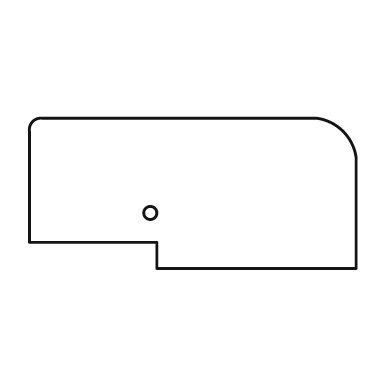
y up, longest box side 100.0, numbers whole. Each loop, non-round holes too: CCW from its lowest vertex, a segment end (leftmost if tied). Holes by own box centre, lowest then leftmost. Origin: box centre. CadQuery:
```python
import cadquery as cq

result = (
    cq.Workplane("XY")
    .moveTo(-11.0, -23.0)
    .lineTo(50.0, -23.0)
    .lineTo(50.0, 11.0)
    .threePointArc((46.0, 19.0), (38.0, 23.0))
    .lineTo(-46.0, 23.0)
    .threePointArc((-49.0, 22.0), (-50.0, 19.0))
    .lineTo(-50.0, -15.0)
    .lineTo(-11.0, -15.0)
    .close()
    .moveTo(-13.0, -6.0)
    .circle(2.0)
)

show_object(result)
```